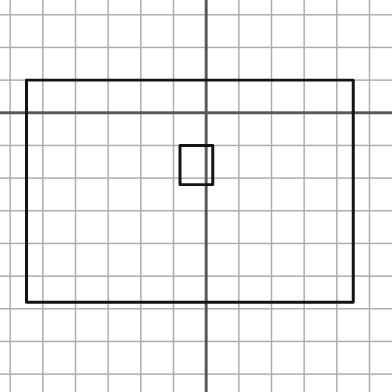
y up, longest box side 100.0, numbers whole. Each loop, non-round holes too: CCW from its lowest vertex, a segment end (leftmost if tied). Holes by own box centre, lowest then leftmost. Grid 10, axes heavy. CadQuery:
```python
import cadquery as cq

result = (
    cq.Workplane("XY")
    .moveTo(-55.0, -58.0)
    .lineTo(45.0, -58.0)
    .lineTo(45.0, 10.0)
    .lineTo(-55.0, 10.0)
    .close()
    .moveTo(-8.0, -22.0)
    .lineTo(2.0, -22.0)
    .lineTo(2.0, -10.0)
    .lineTo(-8.0, -10.0)
    .close()
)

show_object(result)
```